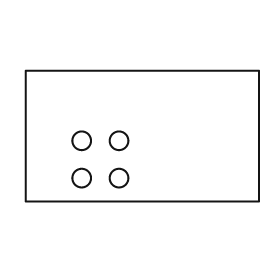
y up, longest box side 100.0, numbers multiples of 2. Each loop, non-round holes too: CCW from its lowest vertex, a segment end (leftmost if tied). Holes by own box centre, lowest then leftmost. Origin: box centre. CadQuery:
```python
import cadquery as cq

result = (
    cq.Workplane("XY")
    .moveTo(-50.0, -28.0)
    .lineTo(50.0, -28.0)
    .lineTo(50.0, 28.0)
    .lineTo(-50.0, 28.0)
    .close()
    .moveTo(-26.0, -18.0)
    .circle(4.0)
    .moveTo(-10.0, -18.0)
    .circle(4.0)
    .moveTo(-26.0, -2.0)
    .circle(4.0)
    .moveTo(-10.0, -2.0)
    .circle(4.0)
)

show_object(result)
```